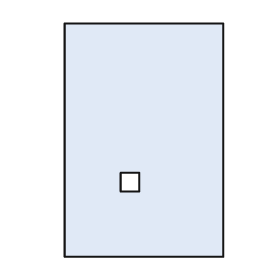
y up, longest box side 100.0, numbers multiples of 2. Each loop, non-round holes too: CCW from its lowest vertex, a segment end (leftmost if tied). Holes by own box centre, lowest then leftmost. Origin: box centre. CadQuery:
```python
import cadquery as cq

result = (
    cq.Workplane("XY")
    .moveTo(-34.0, -50.0)
    .lineTo(34.0, -50.0)
    .lineTo(34.0, 50.0)
    .lineTo(-34.0, 50.0)
    .close()
    .moveTo(-10.0, -22.0)
    .lineTo(-2.0, -22.0)
    .lineTo(-2.0, -14.0)
    .lineTo(-10.0, -14.0)
    .close()
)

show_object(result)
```